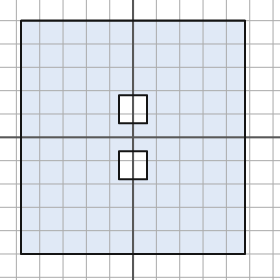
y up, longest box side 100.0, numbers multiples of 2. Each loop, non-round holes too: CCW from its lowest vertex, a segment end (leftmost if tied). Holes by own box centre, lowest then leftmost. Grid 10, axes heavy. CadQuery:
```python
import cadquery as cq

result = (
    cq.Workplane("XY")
    .moveTo(-48.0, -50.0)
    .lineTo(48.0, -50.0)
    .lineTo(48.0, 50.0)
    .lineTo(-48.0, 50.0)
    .close()
    .moveTo(-6.0, -18.0)
    .lineTo(6.0, -18.0)
    .lineTo(6.0, -6.0)
    .lineTo(-6.0, -6.0)
    .close()
    .moveTo(-6.0, 6.0)
    .lineTo(6.0, 6.0)
    .lineTo(6.0, 18.0)
    .lineTo(-6.0, 18.0)
    .close()
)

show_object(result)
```